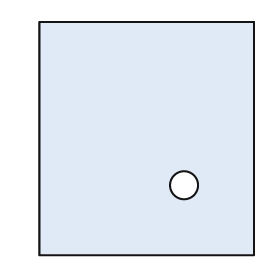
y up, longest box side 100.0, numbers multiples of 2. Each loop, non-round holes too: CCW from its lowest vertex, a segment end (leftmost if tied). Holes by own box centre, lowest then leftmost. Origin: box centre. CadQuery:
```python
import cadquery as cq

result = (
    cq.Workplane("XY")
    .moveTo(-46.0, -50.0)
    .lineTo(46.0, -50.0)
    .lineTo(46.0, 50.0)
    .lineTo(-46.0, 50.0)
    .close()
    .moveTo(16.0, -20.0)
    .circle(6.0)
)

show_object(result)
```